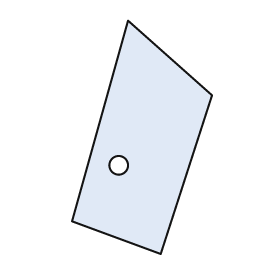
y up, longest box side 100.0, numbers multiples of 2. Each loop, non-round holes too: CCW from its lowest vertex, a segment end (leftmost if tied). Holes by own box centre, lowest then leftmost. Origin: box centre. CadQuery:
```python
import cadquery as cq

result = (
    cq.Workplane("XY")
    .moveTo(8.0, -50.0)
    .lineTo(30.0, 18.0)
    .lineTo(-6.0, 50.0)
    .lineTo(-30.0, -36.0)
    .close()
    .moveTo(-10.0, -12.0)
    .circle(4.0)
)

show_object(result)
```